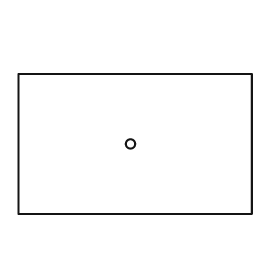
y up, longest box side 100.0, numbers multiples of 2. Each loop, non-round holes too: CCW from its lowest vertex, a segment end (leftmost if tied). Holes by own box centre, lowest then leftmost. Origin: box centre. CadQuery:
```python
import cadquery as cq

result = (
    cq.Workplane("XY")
    .moveTo(-50.0, -30.0)
    .lineTo(50.0, -30.0)
    .lineTo(50.0, 30.0)
    .lineTo(-50.0, 30.0)
    .close()
    .moveTo(-2.0, 0.0)
    .circle(2.0)
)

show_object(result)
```